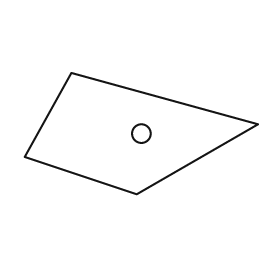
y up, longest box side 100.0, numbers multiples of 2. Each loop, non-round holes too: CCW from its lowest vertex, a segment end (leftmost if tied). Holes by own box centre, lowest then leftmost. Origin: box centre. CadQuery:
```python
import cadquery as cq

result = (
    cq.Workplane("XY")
    .moveTo(-2.0, -26.0)
    .lineTo(50.0, 4.0)
    .lineTo(-30.0, 26.0)
    .lineTo(-50.0, -10.0)
    .close()
    .moveTo(0.0, 0.0)
    .circle(4.0)
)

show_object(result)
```